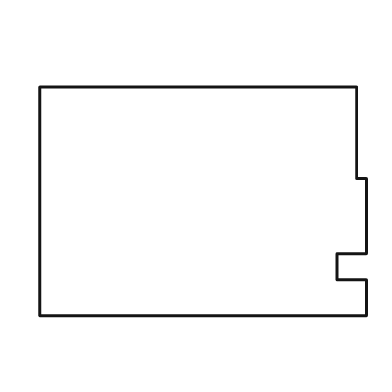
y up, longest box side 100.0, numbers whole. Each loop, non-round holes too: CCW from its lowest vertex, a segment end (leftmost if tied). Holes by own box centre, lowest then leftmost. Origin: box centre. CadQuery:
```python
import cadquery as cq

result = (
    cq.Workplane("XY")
    .moveTo(-50.0, -35.0)
    .lineTo(50.0, -35.0)
    .lineTo(50.0, -24.0)
    .lineTo(41.0, -24.0)
    .lineTo(41.0, -16.0)
    .lineTo(50.0, -16.0)
    .lineTo(50.0, 7.0)
    .lineTo(47.0, 7.0)
    .lineTo(47.0, 35.0)
    .lineTo(-50.0, 35.0)
    .close()
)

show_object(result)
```